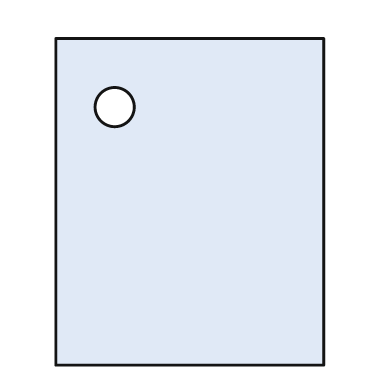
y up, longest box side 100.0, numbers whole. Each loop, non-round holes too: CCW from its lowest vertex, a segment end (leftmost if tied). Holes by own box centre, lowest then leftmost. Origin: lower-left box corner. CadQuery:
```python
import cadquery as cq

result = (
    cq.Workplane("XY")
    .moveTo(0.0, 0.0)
    .lineTo(82.0, 0.0)
    .lineTo(82.0, 100.0)
    .lineTo(0.0, 100.0)
    .close()
    .moveTo(18.0, 79.0)
    .circle(6.0)
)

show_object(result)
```